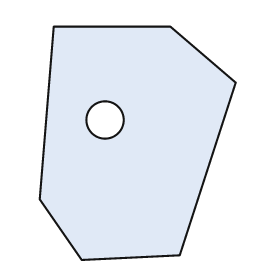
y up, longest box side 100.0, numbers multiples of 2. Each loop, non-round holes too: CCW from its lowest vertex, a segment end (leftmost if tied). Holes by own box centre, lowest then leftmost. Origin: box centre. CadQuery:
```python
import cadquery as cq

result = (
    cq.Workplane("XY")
    .moveTo(-24.0, -50.0)
    .lineTo(18.0, -48.0)
    .lineTo(42.0, 26.0)
    .lineTo(14.0, 50.0)
    .lineTo(-36.0, 50.0)
    .lineTo(-42.0, -24.0)
    .close()
    .moveTo(-14.0, 10.0)
    .circle(8.0)
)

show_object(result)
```